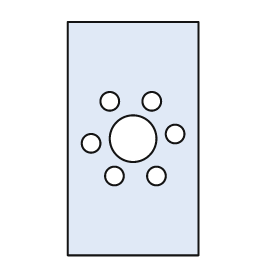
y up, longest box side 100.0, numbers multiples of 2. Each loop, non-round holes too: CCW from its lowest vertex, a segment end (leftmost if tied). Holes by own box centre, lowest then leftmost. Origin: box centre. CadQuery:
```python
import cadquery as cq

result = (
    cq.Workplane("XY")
    .moveTo(-28.0, -50.0)
    .lineTo(28.0, -50.0)
    .lineTo(28.0, 50.0)
    .lineTo(-28.0, 50.0)
    .close()
    .moveTo(-8.0, -16.0)
    .circle(4.0)
    .moveTo(10.0, -16.0)
    .circle(4.0)
    .moveTo(-18.0, -2.0)
    .circle(4.0)
    .moveTo(0.0, 0.0)
    .circle(10.0)
    .moveTo(18.0, 2.0)
    .circle(4.0)
    .moveTo(-10.0, 16.0)
    .circle(4.0)
    .moveTo(8.0, 16.0)
    .circle(4.0)
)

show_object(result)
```